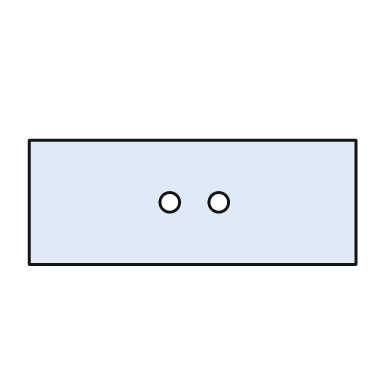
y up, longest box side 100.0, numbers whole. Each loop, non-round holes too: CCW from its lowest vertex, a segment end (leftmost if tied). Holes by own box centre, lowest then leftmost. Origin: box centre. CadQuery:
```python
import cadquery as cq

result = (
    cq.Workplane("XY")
    .moveTo(-50.0, -19.0)
    .lineTo(50.0, -19.0)
    .lineTo(50.0, 19.0)
    .lineTo(-50.0, 19.0)
    .close()
    .moveTo(-7.0, 0.0)
    .circle(3.0)
    .moveTo(8.0, 0.0)
    .circle(3.0)
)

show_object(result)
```